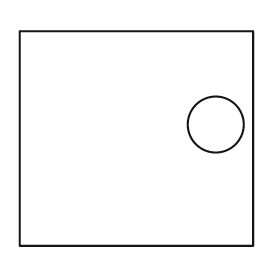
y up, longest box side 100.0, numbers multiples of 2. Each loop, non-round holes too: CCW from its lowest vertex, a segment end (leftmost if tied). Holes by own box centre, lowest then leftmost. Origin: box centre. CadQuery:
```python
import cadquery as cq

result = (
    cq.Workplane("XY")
    .moveTo(-50.0, -46.0)
    .lineTo(50.0, -46.0)
    .lineTo(50.0, 46.0)
    .lineTo(-50.0, 46.0)
    .close()
    .moveTo(34.0, 6.0)
    .circle(12.0)
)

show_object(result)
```